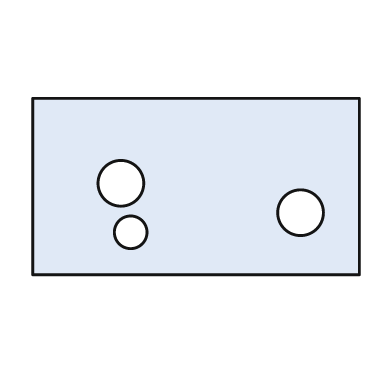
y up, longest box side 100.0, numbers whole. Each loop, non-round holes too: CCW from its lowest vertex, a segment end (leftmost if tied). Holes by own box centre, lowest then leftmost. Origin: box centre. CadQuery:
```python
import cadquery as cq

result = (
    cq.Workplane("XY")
    .moveTo(-50.0, -27.0)
    .lineTo(50.0, -27.0)
    .lineTo(50.0, 27.0)
    .lineTo(-50.0, 27.0)
    .close()
    .moveTo(-20.0, -14.0)
    .circle(5.0)
    .moveTo(32.0, -8.0)
    .circle(7.0)
    .moveTo(-23.0, 1.0)
    .circle(7.0)
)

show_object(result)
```